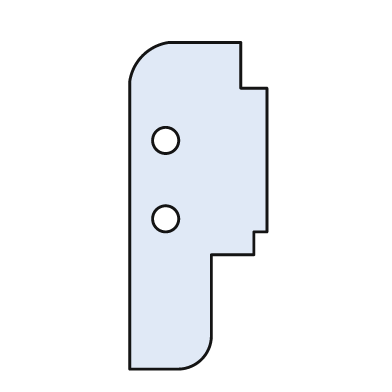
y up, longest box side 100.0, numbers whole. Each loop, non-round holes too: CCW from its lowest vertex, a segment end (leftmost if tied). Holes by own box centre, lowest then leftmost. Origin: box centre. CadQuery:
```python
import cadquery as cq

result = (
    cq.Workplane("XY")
    .moveTo(-21.0, -50.0)
    .lineTo(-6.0, -50.0)
    .threePointArc((1.0, -47.0), (4.0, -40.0))
    .lineTo(4.0, -15.0)
    .lineTo(17.0, -15.0)
    .lineTo(17.0, -8.0)
    .lineTo(21.0, -8.0)
    .lineTo(21.0, 36.0)
    .lineTo(13.0, 36.0)
    .lineTo(13.0, 50.0)
    .lineTo(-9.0, 50.0)
    .threePointArc((-17.0, 46.0), (-21.0, 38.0))
    .close()
    .moveTo(-10.0, -4.0)
    .circle(4.0)
    .moveTo(-10.0, 20.0)
    .circle(4.0)
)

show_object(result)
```